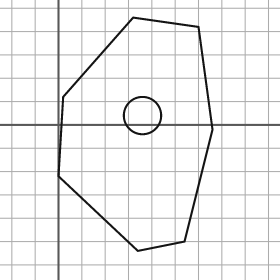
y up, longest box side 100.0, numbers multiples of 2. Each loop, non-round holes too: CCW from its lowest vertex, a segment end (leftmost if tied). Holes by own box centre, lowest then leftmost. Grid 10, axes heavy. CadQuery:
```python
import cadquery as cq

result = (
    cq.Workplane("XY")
    .moveTo(34.0, -54.0)
    .lineTo(54.0, -50.0)
    .lineTo(66.0, -2.0)
    .lineTo(60.0, 42.0)
    .lineTo(32.0, 46.0)
    .lineTo(2.0, 12.0)
    .lineTo(0.0, -22.0)
    .close()
    .moveTo(36.0, 4.0)
    .circle(8.0)
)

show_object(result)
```